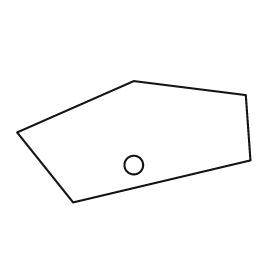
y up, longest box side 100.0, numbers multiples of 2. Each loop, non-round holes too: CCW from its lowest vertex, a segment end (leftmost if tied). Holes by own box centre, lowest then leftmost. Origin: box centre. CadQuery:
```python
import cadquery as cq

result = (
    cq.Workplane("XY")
    .moveTo(-26.0, -26.0)
    .lineTo(50.0, -8.0)
    .lineTo(48.0, 20.0)
    .lineTo(0.0, 26.0)
    .lineTo(-50.0, 4.0)
    .close()
    .moveTo(0.0, -10.0)
    .circle(4.0)
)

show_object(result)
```